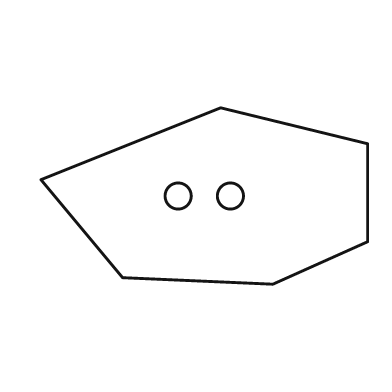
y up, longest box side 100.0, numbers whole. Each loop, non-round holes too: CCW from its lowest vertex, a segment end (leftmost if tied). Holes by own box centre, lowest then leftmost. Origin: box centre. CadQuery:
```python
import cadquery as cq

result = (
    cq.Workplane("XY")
    .moveTo(21.0, -27.0)
    .lineTo(50.0, -14.0)
    .lineTo(50.0, 16.0)
    .lineTo(5.0, 27.0)
    .lineTo(-50.0, 5.0)
    .lineTo(-25.0, -25.0)
    .close()
    .moveTo(-8.0, 0.0)
    .circle(4.0)
    .moveTo(8.0, 0.0)
    .circle(4.0)
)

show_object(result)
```